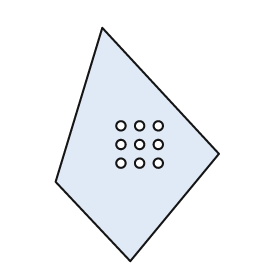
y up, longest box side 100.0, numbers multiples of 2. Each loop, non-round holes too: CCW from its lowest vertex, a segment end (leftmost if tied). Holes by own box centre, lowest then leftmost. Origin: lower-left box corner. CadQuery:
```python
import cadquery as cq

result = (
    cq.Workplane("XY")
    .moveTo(32.0, 0.0)
    .lineTo(70.0, 46.0)
    .lineTo(20.0, 100.0)
    .lineTo(0.0, 34.0)
    .close()
    .moveTo(28.0, 42.0)
    .circle(2.0)
    .moveTo(36.0, 42.0)
    .circle(2.0)
    .moveTo(44.0, 42.0)
    .circle(2.0)
    .moveTo(28.0, 50.0)
    .circle(2.0)
    .moveTo(36.0, 50.0)
    .circle(2.0)
    .moveTo(44.0, 50.0)
    .circle(2.0)
    .moveTo(28.0, 58.0)
    .circle(2.0)
    .moveTo(36.0, 58.0)
    .circle(2.0)
    .moveTo(44.0, 58.0)
    .circle(2.0)
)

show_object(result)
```